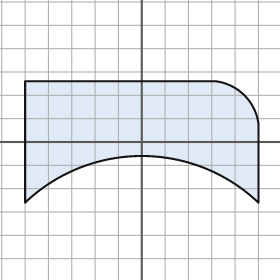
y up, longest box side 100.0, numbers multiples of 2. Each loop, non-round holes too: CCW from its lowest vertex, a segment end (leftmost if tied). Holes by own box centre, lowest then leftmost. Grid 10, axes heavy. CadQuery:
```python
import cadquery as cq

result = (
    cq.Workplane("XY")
    .moveTo(-50.0, -26.0)
    .threePointArc((0.0, -6.0), (50.0, -26.0))
    .lineTo(50.0, 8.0)
    .threePointArc((44.0, 20.0), (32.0, 26.0))
    .lineTo(-50.0, 26.0)
    .close()
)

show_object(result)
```